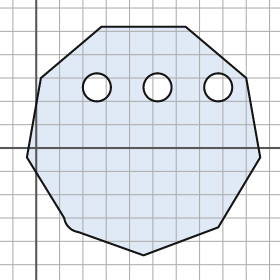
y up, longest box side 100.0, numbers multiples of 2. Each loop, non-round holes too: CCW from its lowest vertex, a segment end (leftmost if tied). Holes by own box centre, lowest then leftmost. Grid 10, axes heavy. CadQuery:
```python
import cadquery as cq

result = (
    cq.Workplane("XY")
    .moveTo(46.0, -46.0)
    .lineTo(78.0, -34.0)
    .lineTo(96.0, -4.0)
    .lineTo(90.0, 30.0)
    .lineTo(64.0, 52.0)
    .lineTo(28.0, 52.0)
    .lineTo(2.0, 30.0)
    .lineTo(-4.0, -4.0)
    .lineTo(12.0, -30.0)
    .threePointArc((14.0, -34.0), (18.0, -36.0))
    .close()
    .moveTo(26.0, 26.0)
    .circle(6.0)
    .moveTo(52.0, 26.0)
    .circle(6.0)
    .moveTo(78.0, 26.0)
    .circle(6.0)
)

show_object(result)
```